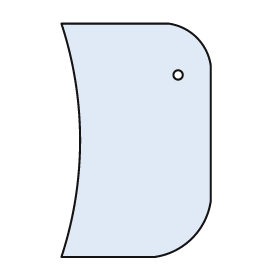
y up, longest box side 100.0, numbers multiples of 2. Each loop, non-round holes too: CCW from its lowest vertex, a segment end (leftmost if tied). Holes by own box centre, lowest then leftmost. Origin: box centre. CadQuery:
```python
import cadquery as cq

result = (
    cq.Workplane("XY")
    .moveTo(-32.0, -50.0)
    .lineTo(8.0, -50.0)
    .threePointArc((24.0, -42.0), (32.0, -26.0))
    .lineTo(32.0, 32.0)
    .threePointArc((26.0, 44.0), (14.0, 50.0))
    .lineTo(-32.0, 50.0)
    .threePointArc((-24.0, 0.0), (-32.0, -50.0))
    .close()
    .moveTo(18.0, 28.0)
    .circle(2.0)
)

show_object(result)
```